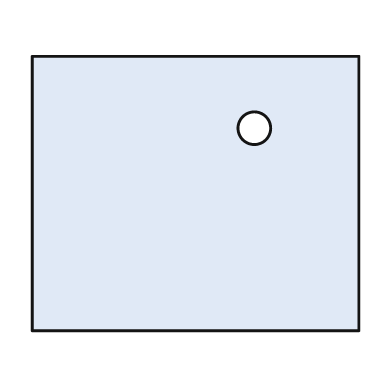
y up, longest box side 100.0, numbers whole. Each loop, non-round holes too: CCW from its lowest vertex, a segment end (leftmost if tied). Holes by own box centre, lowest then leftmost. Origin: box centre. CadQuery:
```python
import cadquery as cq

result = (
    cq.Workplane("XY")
    .moveTo(-50.0, -42.0)
    .lineTo(50.0, -42.0)
    .lineTo(50.0, 42.0)
    .lineTo(-50.0, 42.0)
    .close()
    .moveTo(18.0, 20.0)
    .circle(5.0)
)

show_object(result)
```